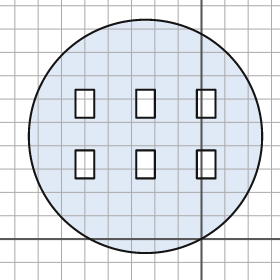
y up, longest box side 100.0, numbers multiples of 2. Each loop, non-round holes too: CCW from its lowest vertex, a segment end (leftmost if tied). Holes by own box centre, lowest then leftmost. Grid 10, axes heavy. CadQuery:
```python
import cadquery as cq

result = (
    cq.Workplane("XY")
    .moveTo(-24.0, 44.0)
    .circle(50.0)
    .moveTo(-54.0, 26.0)
    .lineTo(-46.0, 26.0)
    .lineTo(-46.0, 38.0)
    .lineTo(-54.0, 38.0)
    .close()
    .moveTo(-28.0, 26.0)
    .lineTo(-20.0, 26.0)
    .lineTo(-20.0, 38.0)
    .lineTo(-28.0, 38.0)
    .close()
    .moveTo(-2.0, 26.0)
    .lineTo(6.0, 26.0)
    .lineTo(6.0, 38.0)
    .lineTo(-2.0, 38.0)
    .close()
    .moveTo(-54.0, 52.0)
    .lineTo(-46.0, 52.0)
    .lineTo(-46.0, 64.0)
    .lineTo(-54.0, 64.0)
    .close()
    .moveTo(-28.0, 52.0)
    .lineTo(-20.0, 52.0)
    .lineTo(-20.0, 64.0)
    .lineTo(-28.0, 64.0)
    .close()
    .moveTo(-2.0, 52.0)
    .lineTo(6.0, 52.0)
    .lineTo(6.0, 64.0)
    .lineTo(-2.0, 64.0)
    .close()
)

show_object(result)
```